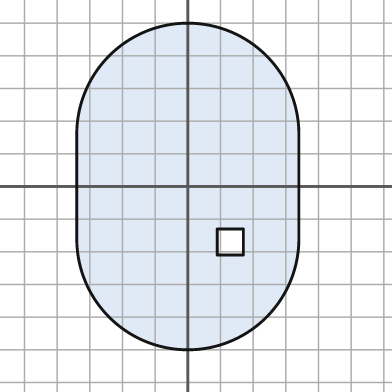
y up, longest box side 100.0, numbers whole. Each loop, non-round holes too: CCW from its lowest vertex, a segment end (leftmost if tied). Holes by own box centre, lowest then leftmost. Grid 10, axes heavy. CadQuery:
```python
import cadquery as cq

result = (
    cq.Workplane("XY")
    .moveTo(-34.0, -16.0)
    .threePointArc((0.0, -50.0), (34.0, -16.0))
    .lineTo(34.0, 16.0)
    .threePointArc((0.0, 50.0), (-34.0, 16.0))
    .close()
    .moveTo(9.0, -21.0)
    .lineTo(17.0, -21.0)
    .lineTo(17.0, -13.0)
    .lineTo(9.0, -13.0)
    .close()
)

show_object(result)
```